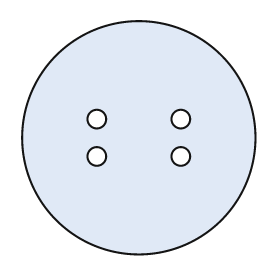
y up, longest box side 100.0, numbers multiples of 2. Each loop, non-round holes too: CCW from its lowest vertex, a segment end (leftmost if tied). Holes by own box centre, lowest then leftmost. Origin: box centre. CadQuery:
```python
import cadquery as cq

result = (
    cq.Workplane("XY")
    .moveTo(0.0, 0.0)
    .circle(50.0)
    .moveTo(-18.0, -8.0)
    .circle(4.0)
    .moveTo(18.0, -8.0)
    .circle(4.0)
    .moveTo(-18.0, 8.0)
    .circle(4.0)
    .moveTo(18.0, 8.0)
    .circle(4.0)
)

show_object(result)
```